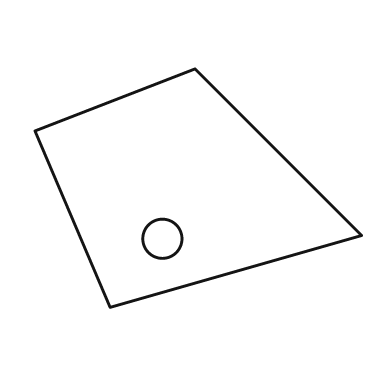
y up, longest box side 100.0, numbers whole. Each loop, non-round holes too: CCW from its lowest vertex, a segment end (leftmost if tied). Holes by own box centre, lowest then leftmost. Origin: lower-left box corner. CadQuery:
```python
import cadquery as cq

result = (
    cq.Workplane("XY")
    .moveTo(23.0, 0.0)
    .lineTo(100.0, 22.0)
    .lineTo(49.0, 73.0)
    .lineTo(0.0, 54.0)
    .close()
    .moveTo(39.0, 21.0)
    .circle(6.0)
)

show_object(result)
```